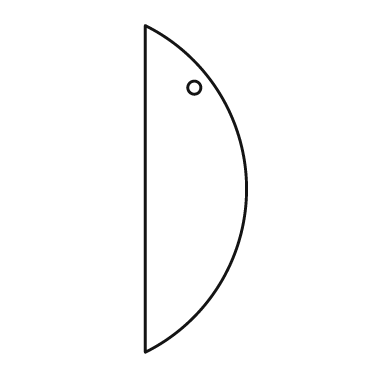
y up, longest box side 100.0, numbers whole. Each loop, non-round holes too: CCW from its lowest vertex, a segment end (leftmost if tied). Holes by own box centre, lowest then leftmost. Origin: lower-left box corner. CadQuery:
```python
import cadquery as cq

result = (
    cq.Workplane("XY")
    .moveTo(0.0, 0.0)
    .threePointArc((31.0, 50.0), (0.0, 100.0))
    .close()
    .moveTo(15.0, 81.0)
    .circle(2.0)
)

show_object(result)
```